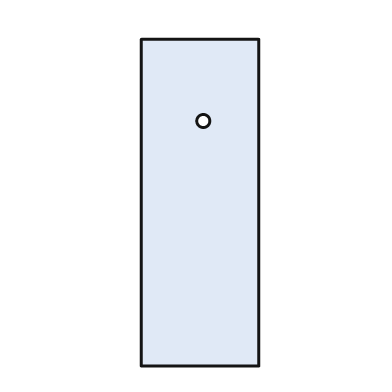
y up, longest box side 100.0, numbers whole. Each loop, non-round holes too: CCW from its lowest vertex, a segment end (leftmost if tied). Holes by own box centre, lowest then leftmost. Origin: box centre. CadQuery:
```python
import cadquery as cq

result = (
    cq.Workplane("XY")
    .moveTo(-18.0, -50.0)
    .lineTo(18.0, -50.0)
    .lineTo(18.0, 50.0)
    .lineTo(-18.0, 50.0)
    .close()
    .moveTo(1.0, 25.0)
    .circle(2.0)
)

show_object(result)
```